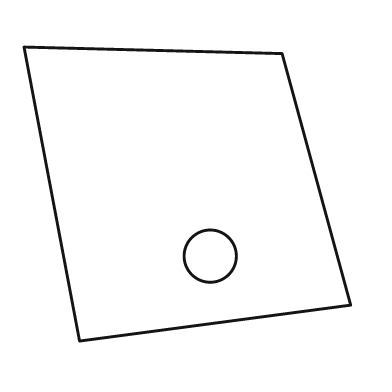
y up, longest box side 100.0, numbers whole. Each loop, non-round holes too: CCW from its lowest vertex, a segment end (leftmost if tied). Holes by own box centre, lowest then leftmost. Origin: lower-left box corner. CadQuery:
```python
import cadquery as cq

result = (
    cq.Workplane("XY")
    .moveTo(17.0, 0.0)
    .lineTo(100.0, 11.0)
    .lineTo(79.0, 88.0)
    .lineTo(0.0, 90.0)
    .close()
    .moveTo(57.0, 26.0)
    .circle(8.0)
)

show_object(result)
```